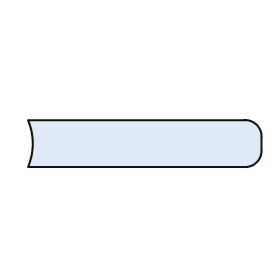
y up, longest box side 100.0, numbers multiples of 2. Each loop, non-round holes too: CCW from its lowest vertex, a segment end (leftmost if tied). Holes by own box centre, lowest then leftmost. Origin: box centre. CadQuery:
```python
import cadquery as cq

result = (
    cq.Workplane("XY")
    .moveTo(-50.0, -10.0)
    .lineTo(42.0, -10.0)
    .threePointArc((48.0, -8.0), (50.0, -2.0))
    .lineTo(50.0, 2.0)
    .threePointArc((48.0, 8.0), (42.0, 10.0))
    .lineTo(-50.0, 10.0)
    .threePointArc((-48.0, 0.0), (-50.0, -10.0))
    .close()
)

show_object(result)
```